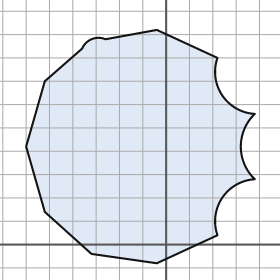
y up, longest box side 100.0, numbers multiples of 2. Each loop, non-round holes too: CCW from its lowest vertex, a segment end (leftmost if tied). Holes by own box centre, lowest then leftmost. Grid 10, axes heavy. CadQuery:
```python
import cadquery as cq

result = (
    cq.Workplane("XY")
    .moveTo(-4.0, -8.0)
    .lineTo(22.0, 4.0)
    .threePointArc((24.0, 20.0), (38.0, 28.0))
    .threePointArc((32.0, 42.0), (38.0, 56.0))
    .threePointArc((24.0, 64.0), (22.0, 80.0))
    .lineTo(-4.0, 92.0)
    .lineTo(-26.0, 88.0)
    .threePointArc((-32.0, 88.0), (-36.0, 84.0))
    .lineTo(-52.0, 70.0)
    .lineTo(-60.0, 42.0)
    .lineTo(-52.0, 14.0)
    .lineTo(-32.0, -4.0)
    .close()
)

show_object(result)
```